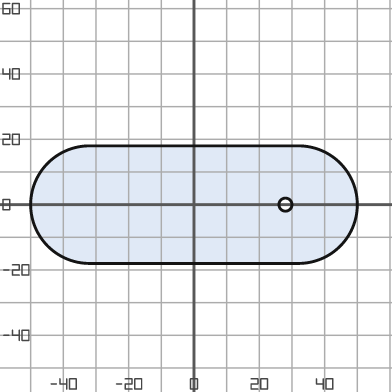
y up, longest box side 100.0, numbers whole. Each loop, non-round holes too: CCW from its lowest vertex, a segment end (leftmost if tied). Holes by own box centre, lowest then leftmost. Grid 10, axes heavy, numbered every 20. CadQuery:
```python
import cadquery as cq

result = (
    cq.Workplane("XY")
    .moveTo(-32.0, -18.0)
    .lineTo(32.0, -18.0)
    .threePointArc((50.0, 0.0), (32.0, 18.0))
    .lineTo(-32.0, 18.0)
    .threePointArc((-50.0, 0.0), (-32.0, -18.0))
    .close()
    .moveTo(28.0, 0.0)
    .circle(2.0)
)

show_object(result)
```